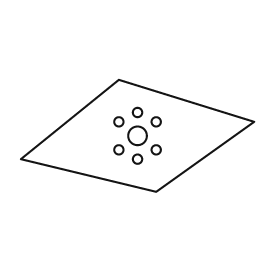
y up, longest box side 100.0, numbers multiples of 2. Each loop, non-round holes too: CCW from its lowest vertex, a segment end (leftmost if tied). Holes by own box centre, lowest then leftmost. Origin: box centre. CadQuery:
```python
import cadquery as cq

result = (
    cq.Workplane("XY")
    .moveTo(8.0, -24.0)
    .lineTo(50.0, 6.0)
    .lineTo(-8.0, 24.0)
    .lineTo(-50.0, -10.0)
    .close()
    .moveTo(0.0, -10.0)
    .circle(2.0)
    .moveTo(-8.0, -6.0)
    .circle(2.0)
    .moveTo(8.0, -6.0)
    .circle(2.0)
    .moveTo(0.0, 0.0)
    .circle(4.0)
    .moveTo(-8.0, 6.0)
    .circle(2.0)
    .moveTo(8.0, 6.0)
    .circle(2.0)
    .moveTo(0.0, 10.0)
    .circle(2.0)
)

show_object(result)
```